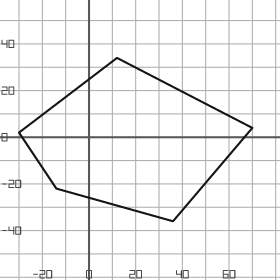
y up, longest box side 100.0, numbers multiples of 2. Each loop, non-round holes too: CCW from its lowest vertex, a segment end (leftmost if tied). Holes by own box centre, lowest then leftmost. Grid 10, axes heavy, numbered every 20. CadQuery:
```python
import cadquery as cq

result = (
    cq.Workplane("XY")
    .moveTo(36.0, -36.0)
    .lineTo(70.0, 4.0)
    .lineTo(12.0, 34.0)
    .lineTo(-30.0, 2.0)
    .lineTo(-14.0, -22.0)
    .close()
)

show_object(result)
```